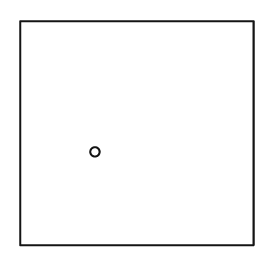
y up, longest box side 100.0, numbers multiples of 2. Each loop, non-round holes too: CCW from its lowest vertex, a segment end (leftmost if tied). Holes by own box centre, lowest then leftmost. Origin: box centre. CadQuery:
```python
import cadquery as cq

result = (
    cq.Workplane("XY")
    .moveTo(-50.0, -48.0)
    .lineTo(50.0, -48.0)
    .lineTo(50.0, 48.0)
    .lineTo(-50.0, 48.0)
    .close()
    .moveTo(-18.0, -8.0)
    .circle(2.0)
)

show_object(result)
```